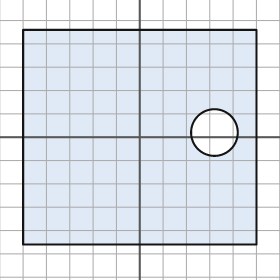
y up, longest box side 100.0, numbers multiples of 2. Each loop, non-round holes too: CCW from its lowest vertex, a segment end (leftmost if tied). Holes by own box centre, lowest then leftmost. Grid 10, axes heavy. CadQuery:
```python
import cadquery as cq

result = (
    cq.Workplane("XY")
    .moveTo(-50.0, -46.0)
    .lineTo(50.0, -46.0)
    .lineTo(50.0, 46.0)
    .lineTo(-50.0, 46.0)
    .close()
    .moveTo(32.0, 2.0)
    .circle(10.0)
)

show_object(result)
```